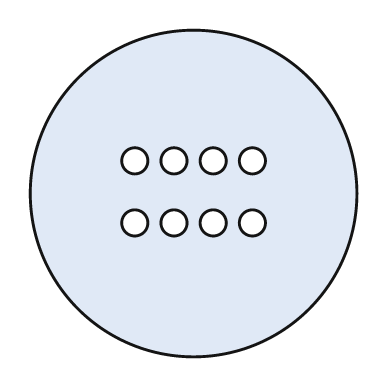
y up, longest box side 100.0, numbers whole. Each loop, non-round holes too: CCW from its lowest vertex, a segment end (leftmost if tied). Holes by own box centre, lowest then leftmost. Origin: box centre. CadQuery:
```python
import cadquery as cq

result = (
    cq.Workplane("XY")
    .moveTo(0.0, 0.0)
    .circle(50.0)
    .moveTo(-18.0, -9.0)
    .circle(4.0)
    .moveTo(-6.0, -9.0)
    .circle(4.0)
    .moveTo(6.0, -9.0)
    .circle(4.0)
    .moveTo(18.0, -9.0)
    .circle(4.0)
    .moveTo(-18.0, 10.0)
    .circle(4.0)
    .moveTo(-6.0, 10.0)
    .circle(4.0)
    .moveTo(6.0, 10.0)
    .circle(4.0)
    .moveTo(18.0, 10.0)
    .circle(4.0)
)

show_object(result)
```